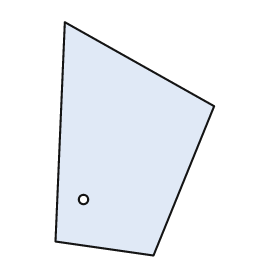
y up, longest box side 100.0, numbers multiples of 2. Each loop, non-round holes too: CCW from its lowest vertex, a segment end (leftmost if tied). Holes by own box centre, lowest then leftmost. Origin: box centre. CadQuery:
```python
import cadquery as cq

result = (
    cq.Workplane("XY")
    .moveTo(8.0, -50.0)
    .lineTo(34.0, 14.0)
    .lineTo(-30.0, 50.0)
    .lineTo(-34.0, -44.0)
    .close()
    .moveTo(-22.0, -26.0)
    .circle(2.0)
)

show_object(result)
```